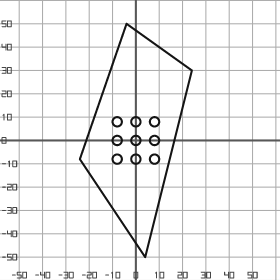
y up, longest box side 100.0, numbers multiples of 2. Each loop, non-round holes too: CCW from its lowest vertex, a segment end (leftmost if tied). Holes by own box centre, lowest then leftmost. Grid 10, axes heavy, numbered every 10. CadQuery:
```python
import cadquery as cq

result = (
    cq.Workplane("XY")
    .moveTo(4.0, -50.0)
    .lineTo(24.0, 30.0)
    .lineTo(-4.0, 50.0)
    .lineTo(-24.0, -8.0)
    .close()
    .moveTo(-8.0, -8.0)
    .circle(2.0)
    .moveTo(0.0, -8.0)
    .circle(2.0)
    .moveTo(8.0, -8.0)
    .circle(2.0)
    .moveTo(-8.0, 0.0)
    .circle(2.0)
    .moveTo(0.0, 0.0)
    .circle(2.0)
    .moveTo(8.0, 0.0)
    .circle(2.0)
    .moveTo(-8.0, 8.0)
    .circle(2.0)
    .moveTo(0.0, 8.0)
    .circle(2.0)
    .moveTo(8.0, 8.0)
    .circle(2.0)
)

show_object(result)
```